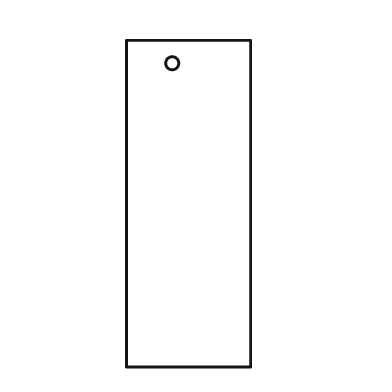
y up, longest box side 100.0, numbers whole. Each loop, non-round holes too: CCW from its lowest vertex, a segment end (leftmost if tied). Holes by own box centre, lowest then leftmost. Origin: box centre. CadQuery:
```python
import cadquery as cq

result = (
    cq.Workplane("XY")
    .moveTo(-19.0, -50.0)
    .lineTo(19.0, -50.0)
    .lineTo(19.0, 50.0)
    .lineTo(-19.0, 50.0)
    .close()
    .moveTo(-5.0, 43.0)
    .circle(2.0)
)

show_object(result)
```